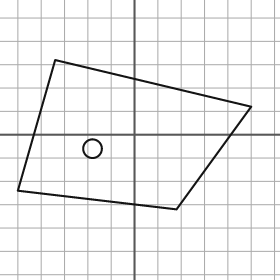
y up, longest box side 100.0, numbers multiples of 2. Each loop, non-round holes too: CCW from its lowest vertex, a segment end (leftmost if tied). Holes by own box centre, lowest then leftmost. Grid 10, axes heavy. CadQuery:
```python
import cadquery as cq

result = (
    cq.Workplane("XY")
    .moveTo(18.0, -32.0)
    .lineTo(50.0, 12.0)
    .lineTo(-34.0, 32.0)
    .lineTo(-50.0, -24.0)
    .close()
    .moveTo(-18.0, -6.0)
    .circle(4.0)
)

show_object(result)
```